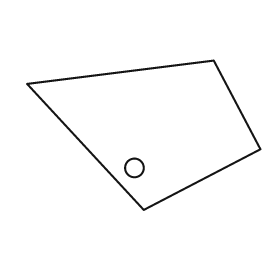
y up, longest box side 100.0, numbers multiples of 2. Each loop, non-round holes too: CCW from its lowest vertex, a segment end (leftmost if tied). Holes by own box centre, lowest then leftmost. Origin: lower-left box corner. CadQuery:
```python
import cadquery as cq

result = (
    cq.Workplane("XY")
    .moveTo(50.0, 0.0)
    .lineTo(100.0, 26.0)
    .lineTo(80.0, 64.0)
    .lineTo(0.0, 54.0)
    .close()
    .moveTo(46.0, 18.0)
    .circle(4.0)
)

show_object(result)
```